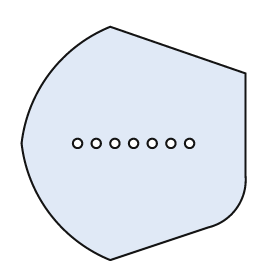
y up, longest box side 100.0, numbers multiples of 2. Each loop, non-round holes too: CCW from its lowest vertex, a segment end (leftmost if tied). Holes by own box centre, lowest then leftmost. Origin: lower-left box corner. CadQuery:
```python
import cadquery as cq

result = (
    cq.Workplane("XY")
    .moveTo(38.0, 0.0)
    .lineTo(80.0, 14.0)
    .threePointArc((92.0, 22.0), (96.0, 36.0))
    .lineTo(96.0, 80.0)
    .lineTo(38.0, 100.0)
    .threePointArc((12.0, 80.0), (0.0, 50.0))
    .threePointArc((12.0, 20.0), (38.0, 0.0))
    .close()
    .moveTo(24.0, 50.0)
    .circle(2.0)
    .moveTo(32.0, 50.0)
    .circle(2.0)
    .moveTo(40.0, 50.0)
    .circle(2.0)
    .moveTo(48.0, 50.0)
    .circle(2.0)
    .moveTo(56.0, 50.0)
    .circle(2.0)
    .moveTo(64.0, 50.0)
    .circle(2.0)
    .moveTo(72.0, 50.0)
    .circle(2.0)
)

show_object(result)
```